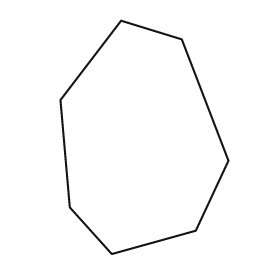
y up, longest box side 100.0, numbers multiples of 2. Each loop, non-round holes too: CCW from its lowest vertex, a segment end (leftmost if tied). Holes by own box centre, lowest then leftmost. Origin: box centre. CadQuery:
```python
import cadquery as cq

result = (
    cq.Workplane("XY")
    .moveTo(-14.0, -50.0)
    .lineTo(22.0, -40.0)
    .lineTo(36.0, -10.0)
    .lineTo(16.0, 42.0)
    .lineTo(-10.0, 50.0)
    .lineTo(-36.0, 16.0)
    .lineTo(-32.0, -30.0)
    .close()
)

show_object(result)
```